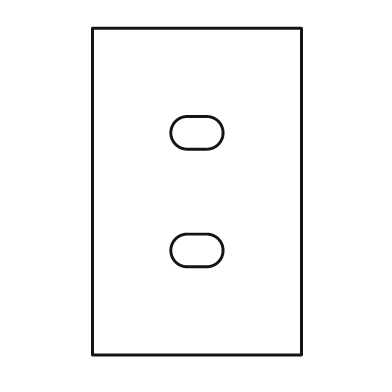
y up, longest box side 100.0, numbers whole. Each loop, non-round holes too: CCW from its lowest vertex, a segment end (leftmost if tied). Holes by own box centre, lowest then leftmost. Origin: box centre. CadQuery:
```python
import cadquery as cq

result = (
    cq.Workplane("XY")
    .moveTo(-32.0, -50.0)
    .lineTo(32.0, -50.0)
    .lineTo(32.0, 50.0)
    .lineTo(-32.0, 50.0)
    .close()
    .moveTo(-3.0, -23.0)
    .lineTo(3.0, -23.0)
    .threePointArc((8.0, -18.0), (3.0, -13.0))
    .lineTo(-3.0, -13.0)
    .threePointArc((-8.0, -18.0), (-3.0, -23.0))
    .close()
    .moveTo(-3.0, 13.0)
    .lineTo(3.0, 13.0)
    .threePointArc((8.0, 18.0), (3.0, 23.0))
    .lineTo(-3.0, 23.0)
    .threePointArc((-8.0, 18.0), (-3.0, 13.0))
    .close()
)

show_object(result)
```